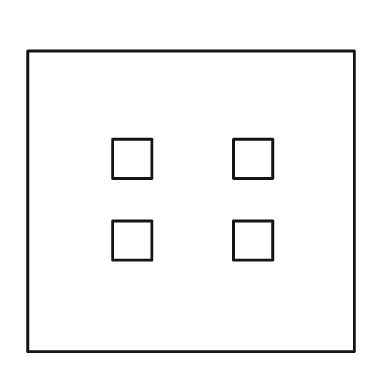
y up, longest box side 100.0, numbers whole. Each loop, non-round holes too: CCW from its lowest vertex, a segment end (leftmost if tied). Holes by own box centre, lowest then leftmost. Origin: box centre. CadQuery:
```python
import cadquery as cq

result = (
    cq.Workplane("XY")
    .moveTo(-50.0, -46.0)
    .lineTo(50.0, -46.0)
    .lineTo(50.0, 46.0)
    .lineTo(-50.0, 46.0)
    .close()
    .moveTo(-24.0, -18.0)
    .lineTo(-12.0, -18.0)
    .lineTo(-12.0, -6.0)
    .lineTo(-24.0, -6.0)
    .close()
    .moveTo(13.0, -18.0)
    .lineTo(25.0, -18.0)
    .lineTo(25.0, -6.0)
    .lineTo(13.0, -6.0)
    .close()
    .moveTo(-24.0, 7.0)
    .lineTo(-12.0, 7.0)
    .lineTo(-12.0, 19.0)
    .lineTo(-24.0, 19.0)
    .close()
    .moveTo(13.0, 7.0)
    .lineTo(25.0, 7.0)
    .lineTo(25.0, 19.0)
    .lineTo(13.0, 19.0)
    .close()
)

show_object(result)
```